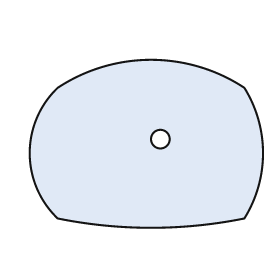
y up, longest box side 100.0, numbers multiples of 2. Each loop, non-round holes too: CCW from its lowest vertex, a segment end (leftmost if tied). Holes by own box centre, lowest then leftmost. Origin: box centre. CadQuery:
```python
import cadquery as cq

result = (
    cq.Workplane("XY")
    .moveTo(-38.0, -32.0)
    .threePointArc((2.0, -36.0), (42.0, -32.0))
    .threePointArc((50.0, -4.0), (42.0, 24.0))
    .threePointArc((2.0, 36.0), (-38.0, 24.0))
    .threePointArc((-50.0, -4.0), (-38.0, -32.0))
    .close()
    .moveTo(6.0, 2.0)
    .circle(4.0)
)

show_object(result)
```